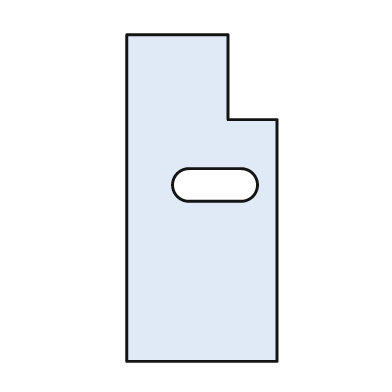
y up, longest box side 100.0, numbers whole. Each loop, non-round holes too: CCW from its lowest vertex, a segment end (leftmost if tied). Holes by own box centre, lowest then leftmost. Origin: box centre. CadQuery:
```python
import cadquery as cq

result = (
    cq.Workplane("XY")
    .moveTo(-23.0, -50.0)
    .lineTo(23.0, -50.0)
    .lineTo(23.0, 24.0)
    .lineTo(8.0, 24.0)
    .lineTo(8.0, 50.0)
    .lineTo(-23.0, 50.0)
    .close()
    .moveTo(-4.0, -1.0)
    .lineTo(12.0, -1.0)
    .threePointArc((17.0, 4.0), (12.0, 9.0))
    .lineTo(-4.0, 9.0)
    .threePointArc((-9.0, 4.0), (-4.0, -1.0))
    .close()
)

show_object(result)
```